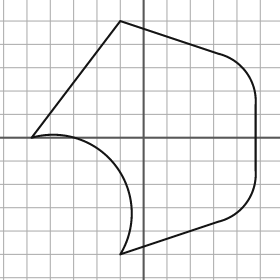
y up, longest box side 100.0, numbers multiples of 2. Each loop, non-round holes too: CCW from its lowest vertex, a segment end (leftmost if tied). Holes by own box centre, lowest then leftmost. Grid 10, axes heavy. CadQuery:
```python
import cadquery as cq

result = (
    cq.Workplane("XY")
    .moveTo(-10.0, -50.0)
    .lineTo(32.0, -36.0)
    .threePointArc((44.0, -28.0), (48.0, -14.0))
    .lineTo(48.0, 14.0)
    .threePointArc((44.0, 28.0), (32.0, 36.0))
    .lineTo(-10.0, 50.0)
    .lineTo(-48.0, 0.0)
    .threePointArc((-12.0, -12.0), (-10.0, -50.0))
    .close()
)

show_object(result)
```